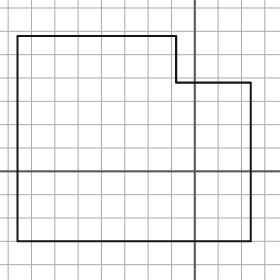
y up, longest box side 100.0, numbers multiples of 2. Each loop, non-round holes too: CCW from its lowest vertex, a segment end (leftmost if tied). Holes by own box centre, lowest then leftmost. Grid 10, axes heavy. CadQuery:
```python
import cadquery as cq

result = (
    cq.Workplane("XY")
    .moveTo(-76.0, -30.0)
    .lineTo(24.0, -30.0)
    .lineTo(24.0, 38.0)
    .lineTo(-8.0, 38.0)
    .lineTo(-8.0, 58.0)
    .lineTo(-76.0, 58.0)
    .close()
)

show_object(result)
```